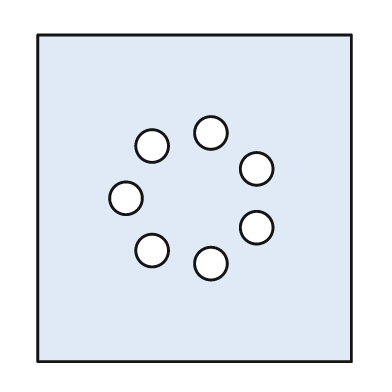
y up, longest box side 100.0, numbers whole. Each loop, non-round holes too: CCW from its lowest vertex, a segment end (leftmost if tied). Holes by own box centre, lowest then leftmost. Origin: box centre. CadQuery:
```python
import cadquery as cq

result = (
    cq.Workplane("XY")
    .moveTo(-48.0, -50.0)
    .lineTo(48.0, -50.0)
    .lineTo(48.0, 50.0)
    .lineTo(-48.0, 50.0)
    .close()
    .moveTo(5.0, -20.0)
    .circle(5.0)
    .moveTo(-13.0, -16.0)
    .circle(5.0)
    .moveTo(19.0, -9.0)
    .circle(5.0)
    .moveTo(-21.0, 0.0)
    .circle(5.0)
    .moveTo(19.0, 9.0)
    .circle(5.0)
    .moveTo(-13.0, 16.0)
    .circle(5.0)
    .moveTo(5.0, 20.0)
    .circle(5.0)
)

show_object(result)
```